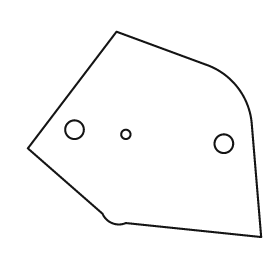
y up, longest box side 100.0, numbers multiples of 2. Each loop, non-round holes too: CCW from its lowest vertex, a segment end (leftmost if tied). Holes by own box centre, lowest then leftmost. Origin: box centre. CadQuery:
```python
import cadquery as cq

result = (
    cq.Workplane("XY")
    .moveTo(50.0, -44.0)
    .lineTo(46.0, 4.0)
    .threePointArc((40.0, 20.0), (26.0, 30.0))
    .lineTo(-12.0, 44.0)
    .lineTo(-50.0, -6.0)
    .lineTo(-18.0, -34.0)
    .threePointArc((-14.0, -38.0), (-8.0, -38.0))
    .close()
    .moveTo(34.0, -4.0)
    .circle(4.0)
    .moveTo(-8.0, 0.0)
    .circle(2.0)
    .moveTo(-30.0, 2.0)
    .circle(4.0)
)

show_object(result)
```